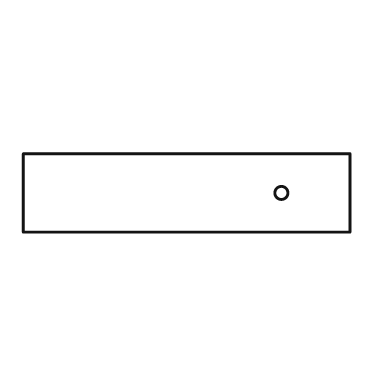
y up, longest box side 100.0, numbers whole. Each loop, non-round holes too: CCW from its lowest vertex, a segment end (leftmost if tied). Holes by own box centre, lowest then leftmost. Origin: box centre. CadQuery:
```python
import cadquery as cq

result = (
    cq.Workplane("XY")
    .moveTo(-50.0, -12.0)
    .lineTo(50.0, -12.0)
    .lineTo(50.0, 12.0)
    .lineTo(-50.0, 12.0)
    .close()
    .moveTo(29.0, 0.0)
    .circle(2.0)
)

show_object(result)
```